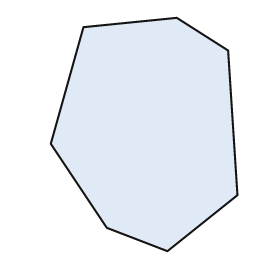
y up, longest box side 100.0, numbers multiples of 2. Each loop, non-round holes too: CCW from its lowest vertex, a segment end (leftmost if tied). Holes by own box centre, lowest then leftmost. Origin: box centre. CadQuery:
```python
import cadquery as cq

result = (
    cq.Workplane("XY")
    .moveTo(10.0, -50.0)
    .lineTo(40.0, -26.0)
    .lineTo(36.0, 36.0)
    .lineTo(14.0, 50.0)
    .lineTo(-26.0, 46.0)
    .lineTo(-40.0, -4.0)
    .lineTo(-16.0, -40.0)
    .close()
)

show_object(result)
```